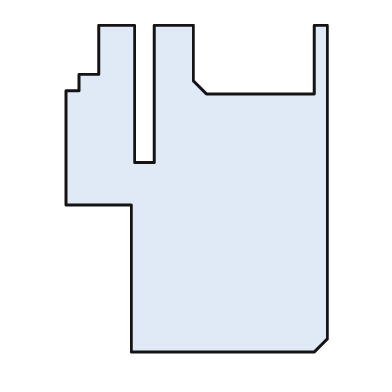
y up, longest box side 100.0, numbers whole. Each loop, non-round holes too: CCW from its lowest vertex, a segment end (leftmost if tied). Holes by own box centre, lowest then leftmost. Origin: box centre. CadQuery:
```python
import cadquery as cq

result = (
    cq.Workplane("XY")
    .moveTo(-20.0, -50.0)
    .lineTo(36.0, -50.0)
    .lineTo(40.0, -46.0)
    .lineTo(40.0, 50.0)
    .lineTo(36.0, 50.0)
    .lineTo(36.0, 29.0)
    .lineTo(3.0, 29.0)
    .lineTo(-1.0, 33.0)
    .lineTo(-1.0, 50.0)
    .lineTo(-13.0, 50.0)
    .lineTo(-13.0, 8.0)
    .lineTo(-19.0, 8.0)
    .lineTo(-19.0, 50.0)
    .lineTo(-30.0, 50.0)
    .lineTo(-30.0, 35.0)
    .lineTo(-36.0, 35.0)
    .lineTo(-36.0, 30.0)
    .lineTo(-40.0, 30.0)
    .lineTo(-40.0, -5.0)
    .lineTo(-20.0, -5.0)
    .close()
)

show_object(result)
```